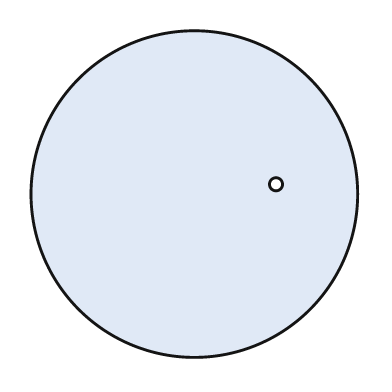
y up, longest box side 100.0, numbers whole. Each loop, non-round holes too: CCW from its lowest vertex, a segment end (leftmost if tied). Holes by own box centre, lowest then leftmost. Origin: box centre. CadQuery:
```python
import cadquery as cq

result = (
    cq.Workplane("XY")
    .moveTo(0.0, 0.0)
    .circle(50.0)
    .moveTo(25.0, 3.0)
    .circle(2.0)
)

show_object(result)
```